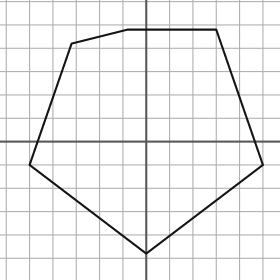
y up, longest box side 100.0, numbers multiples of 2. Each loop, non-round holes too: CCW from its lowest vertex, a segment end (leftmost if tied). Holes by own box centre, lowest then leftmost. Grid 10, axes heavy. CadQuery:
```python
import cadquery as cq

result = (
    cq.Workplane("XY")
    .moveTo(0.0, -48.0)
    .lineTo(50.0, -10.0)
    .lineTo(30.0, 48.0)
    .lineTo(-8.0, 48.0)
    .lineTo(-32.0, 42.0)
    .lineTo(-50.0, -10.0)
    .close()
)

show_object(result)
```